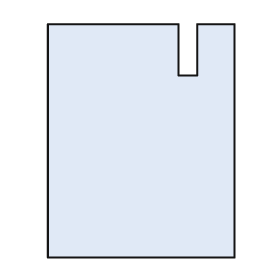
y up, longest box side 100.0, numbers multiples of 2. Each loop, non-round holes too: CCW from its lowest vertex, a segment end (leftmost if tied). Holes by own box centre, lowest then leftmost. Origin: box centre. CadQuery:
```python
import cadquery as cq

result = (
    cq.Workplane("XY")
    .moveTo(-40.0, -50.0)
    .lineTo(40.0, -50.0)
    .lineTo(40.0, 50.0)
    .lineTo(24.0, 50.0)
    .lineTo(24.0, 28.0)
    .lineTo(16.0, 28.0)
    .lineTo(16.0, 50.0)
    .lineTo(-40.0, 50.0)
    .close()
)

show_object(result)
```